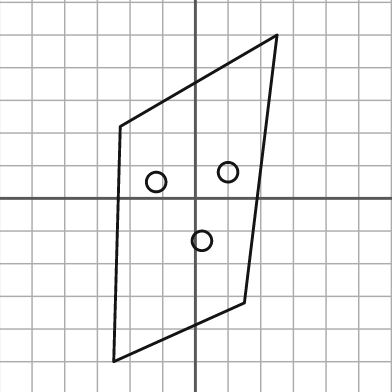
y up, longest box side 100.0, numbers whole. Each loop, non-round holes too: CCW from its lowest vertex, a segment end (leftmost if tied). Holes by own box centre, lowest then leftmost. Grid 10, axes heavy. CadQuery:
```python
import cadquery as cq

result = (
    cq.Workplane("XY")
    .moveTo(-25.0, -50.0)
    .lineTo(15.0, -32.0)
    .lineTo(25.0, 50.0)
    .lineTo(-23.0, 22.0)
    .close()
    .moveTo(2.0, -13.0)
    .circle(3.0)
    .moveTo(-12.0, 5.0)
    .circle(3.0)
    .moveTo(10.0, 8.0)
    .circle(3.0)
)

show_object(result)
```